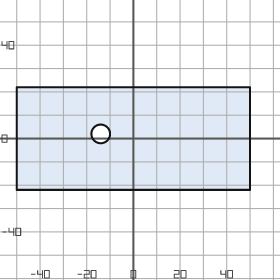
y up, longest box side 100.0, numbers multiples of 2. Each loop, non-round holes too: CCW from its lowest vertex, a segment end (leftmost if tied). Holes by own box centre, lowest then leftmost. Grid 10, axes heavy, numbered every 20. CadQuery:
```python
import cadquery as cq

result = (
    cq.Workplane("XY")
    .moveTo(-50.0, -22.0)
    .lineTo(50.0, -22.0)
    .lineTo(50.0, 22.0)
    .lineTo(-50.0, 22.0)
    .close()
    .moveTo(-14.0, 2.0)
    .circle(4.0)
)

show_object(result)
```